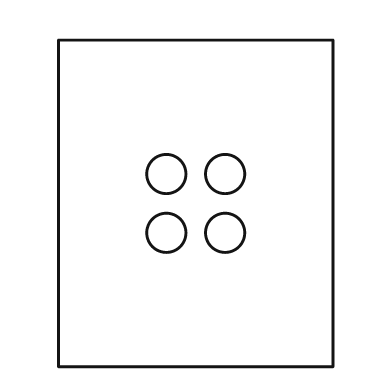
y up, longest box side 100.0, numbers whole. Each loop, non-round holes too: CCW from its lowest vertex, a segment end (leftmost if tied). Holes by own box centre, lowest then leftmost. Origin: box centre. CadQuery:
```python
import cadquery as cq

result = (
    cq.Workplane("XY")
    .moveTo(-42.0, -50.0)
    .lineTo(42.0, -50.0)
    .lineTo(42.0, 50.0)
    .lineTo(-42.0, 50.0)
    .close()
    .moveTo(-9.0, -9.0)
    .circle(6.0)
    .moveTo(9.0, -9.0)
    .circle(6.0)
    .moveTo(-9.0, 9.0)
    .circle(6.0)
    .moveTo(9.0, 9.0)
    .circle(6.0)
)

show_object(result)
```